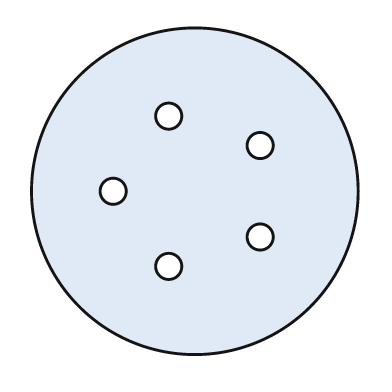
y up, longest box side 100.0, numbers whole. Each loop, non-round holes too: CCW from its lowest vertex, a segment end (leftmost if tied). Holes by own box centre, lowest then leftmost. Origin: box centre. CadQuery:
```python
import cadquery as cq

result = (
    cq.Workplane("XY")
    .moveTo(0.0, 0.0)
    .circle(50.0)
    .moveTo(-8.0, -23.0)
    .circle(4.0)
    .moveTo(20.0, -14.0)
    .circle(4.0)
    .moveTo(-25.0, 0.0)
    .circle(4.0)
    .moveTo(20.0, 14.0)
    .circle(4.0)
    .moveTo(-8.0, 23.0)
    .circle(4.0)
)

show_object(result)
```